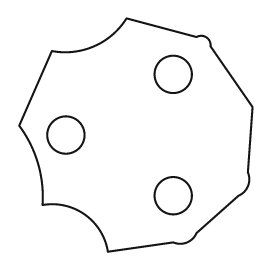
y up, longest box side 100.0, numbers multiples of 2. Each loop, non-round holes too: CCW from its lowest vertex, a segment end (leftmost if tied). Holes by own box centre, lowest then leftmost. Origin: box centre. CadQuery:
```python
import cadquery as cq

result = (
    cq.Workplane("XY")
    .moveTo(-12.0, -50.0)
    .lineTo(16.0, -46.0)
    .threePointArc((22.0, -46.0), (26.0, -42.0))
    .lineTo(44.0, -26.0)
    .threePointArc((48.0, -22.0), (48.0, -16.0))
    .lineTo(50.0, 12.0)
    .lineTo(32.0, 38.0)
    .threePointArc((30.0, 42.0), (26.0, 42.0))
    .lineTo(-4.0, 50.0)
    .threePointArc((-18.0, 38.0), (-36.0, 36.0))
    .lineTo(-50.0, 4.0)
    .threePointArc((-42.0, -12.0), (-40.0, -30.0))
    .threePointArc((-22.0, -34.0), (-12.0, -50.0))
    .close()
    .moveTo(16.0, -26.0)
    .circle(8.0)
    .moveTo(-30.0, 0.0)
    .circle(8.0)
    .moveTo(16.0, 26.0)
    .circle(8.0)
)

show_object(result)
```